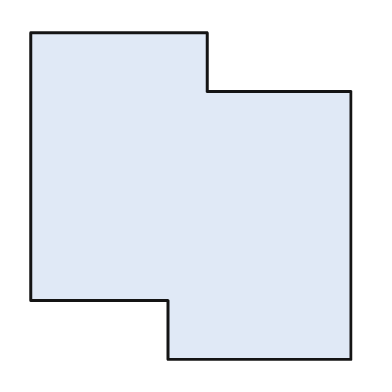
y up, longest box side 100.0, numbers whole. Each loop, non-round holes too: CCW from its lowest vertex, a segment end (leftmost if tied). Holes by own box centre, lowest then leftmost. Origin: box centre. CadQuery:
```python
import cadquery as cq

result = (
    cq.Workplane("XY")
    .moveTo(-7.0, -50.0)
    .lineTo(49.0, -50.0)
    .lineTo(49.0, 32.0)
    .lineTo(5.0, 32.0)
    .lineTo(5.0, 50.0)
    .lineTo(-49.0, 50.0)
    .lineTo(-49.0, -32.0)
    .lineTo(-7.0, -32.0)
    .close()
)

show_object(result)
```